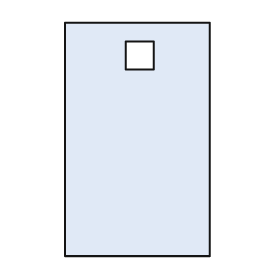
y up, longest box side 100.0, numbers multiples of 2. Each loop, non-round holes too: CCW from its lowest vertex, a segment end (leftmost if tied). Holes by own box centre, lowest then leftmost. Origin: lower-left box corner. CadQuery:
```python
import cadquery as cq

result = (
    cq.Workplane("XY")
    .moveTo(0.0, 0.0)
    .lineTo(62.0, 0.0)
    .lineTo(62.0, 100.0)
    .lineTo(0.0, 100.0)
    .close()
    .moveTo(26.0, 80.0)
    .lineTo(38.0, 80.0)
    .lineTo(38.0, 92.0)
    .lineTo(26.0, 92.0)
    .close()
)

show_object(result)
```